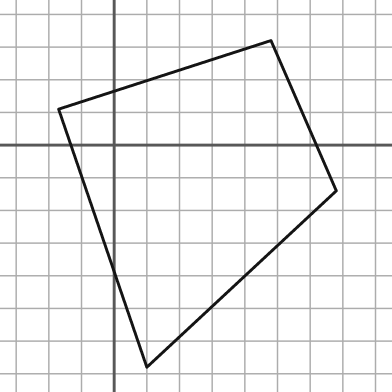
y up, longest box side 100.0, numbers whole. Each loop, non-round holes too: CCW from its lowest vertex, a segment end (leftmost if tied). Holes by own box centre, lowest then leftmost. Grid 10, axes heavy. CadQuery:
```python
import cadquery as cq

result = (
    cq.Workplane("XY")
    .moveTo(10.0, -68.0)
    .lineTo(68.0, -14.0)
    .lineTo(48.0, 32.0)
    .lineTo(-17.0, 11.0)
    .close()
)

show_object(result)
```